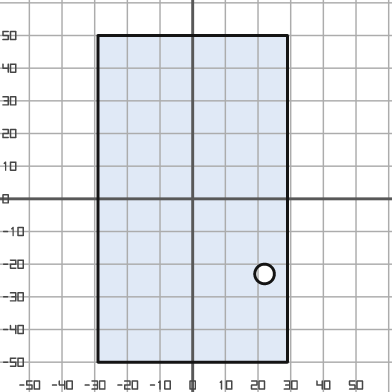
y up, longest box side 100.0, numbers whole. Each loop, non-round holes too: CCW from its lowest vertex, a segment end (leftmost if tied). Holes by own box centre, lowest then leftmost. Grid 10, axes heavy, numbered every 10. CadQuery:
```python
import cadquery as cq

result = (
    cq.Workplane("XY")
    .moveTo(-29.0, -50.0)
    .lineTo(29.0, -50.0)
    .lineTo(29.0, 50.0)
    .lineTo(-29.0, 50.0)
    .close()
    .moveTo(22.0, -23.0)
    .circle(3.0)
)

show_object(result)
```